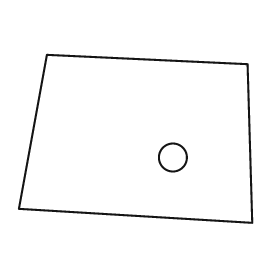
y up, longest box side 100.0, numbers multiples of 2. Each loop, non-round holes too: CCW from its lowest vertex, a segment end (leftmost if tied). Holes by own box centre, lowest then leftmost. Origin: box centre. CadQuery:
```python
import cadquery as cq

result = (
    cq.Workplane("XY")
    .moveTo(50.0, -36.0)
    .lineTo(48.0, 32.0)
    .lineTo(-38.0, 36.0)
    .lineTo(-50.0, -30.0)
    .close()
    .moveTo(16.0, -8.0)
    .circle(6.0)
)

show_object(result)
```